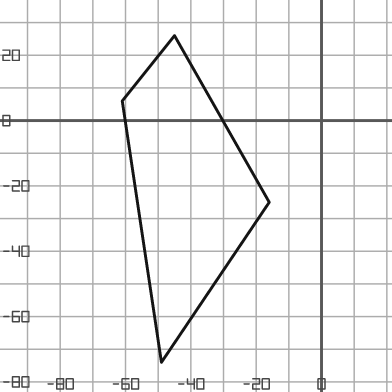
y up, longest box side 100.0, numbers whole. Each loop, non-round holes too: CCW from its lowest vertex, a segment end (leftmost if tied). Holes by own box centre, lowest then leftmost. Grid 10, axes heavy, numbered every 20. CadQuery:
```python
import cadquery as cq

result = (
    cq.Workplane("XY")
    .moveTo(-49.0, -74.0)
    .lineTo(-16.0, -25.0)
    .lineTo(-45.0, 26.0)
    .lineTo(-61.0, 6.0)
    .close()
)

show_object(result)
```